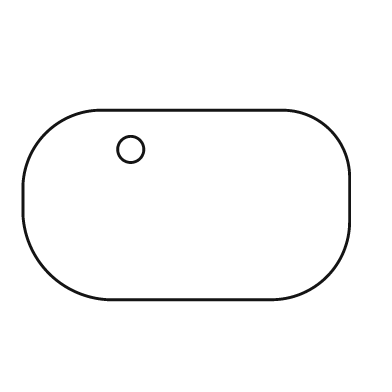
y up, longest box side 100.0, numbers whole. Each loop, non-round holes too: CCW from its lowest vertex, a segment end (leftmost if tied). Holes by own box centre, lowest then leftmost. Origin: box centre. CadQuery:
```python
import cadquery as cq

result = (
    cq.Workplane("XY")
    .moveTo(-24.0, -29.0)
    .lineTo(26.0, -29.0)
    .threePointArc((43.0, -22.0), (50.0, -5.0))
    .lineTo(50.0, 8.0)
    .threePointArc((44.0, 23.0), (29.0, 29.0))
    .lineTo(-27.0, 29.0)
    .threePointArc((-43.0, 22.0), (-50.0, 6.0))
    .lineTo(-50.0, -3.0)
    .threePointArc((-42.0, -21.0), (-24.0, -29.0))
    .close()
    .moveTo(-17.0, 17.0)
    .circle(4.0)
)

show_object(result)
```